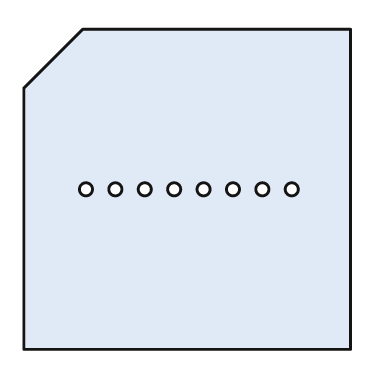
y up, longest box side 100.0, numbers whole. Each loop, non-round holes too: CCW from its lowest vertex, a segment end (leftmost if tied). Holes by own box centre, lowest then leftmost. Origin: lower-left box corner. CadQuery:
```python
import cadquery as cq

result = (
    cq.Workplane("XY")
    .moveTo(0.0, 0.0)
    .lineTo(100.0, 0.0)
    .lineTo(100.0, 98.0)
    .lineTo(18.0, 98.0)
    .lineTo(0.0, 80.0)
    .close()
    .moveTo(19.0, 49.0)
    .circle(2.0)
    .moveTo(28.0, 49.0)
    .circle(2.0)
    .moveTo(37.0, 49.0)
    .circle(2.0)
    .moveTo(46.0, 49.0)
    .circle(2.0)
    .moveTo(55.0, 49.0)
    .circle(2.0)
    .moveTo(64.0, 49.0)
    .circle(2.0)
    .moveTo(73.0, 49.0)
    .circle(2.0)
    .moveTo(82.0, 49.0)
    .circle(2.0)
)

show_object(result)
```